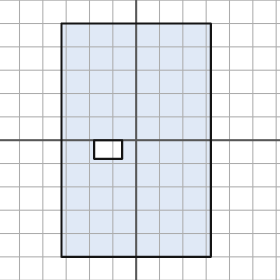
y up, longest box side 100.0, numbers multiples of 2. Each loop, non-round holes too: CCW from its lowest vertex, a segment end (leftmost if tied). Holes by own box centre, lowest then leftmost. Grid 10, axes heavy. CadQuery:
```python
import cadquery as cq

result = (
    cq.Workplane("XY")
    .moveTo(-32.0, -50.0)
    .lineTo(32.0, -50.0)
    .lineTo(32.0, 50.0)
    .lineTo(-32.0, 50.0)
    .close()
    .moveTo(-18.0, -8.0)
    .lineTo(-6.0, -8.0)
    .lineTo(-6.0, 0.0)
    .lineTo(-18.0, 0.0)
    .close()
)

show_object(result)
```